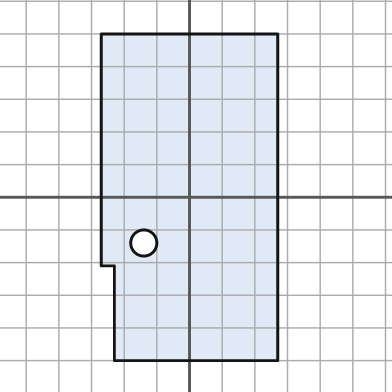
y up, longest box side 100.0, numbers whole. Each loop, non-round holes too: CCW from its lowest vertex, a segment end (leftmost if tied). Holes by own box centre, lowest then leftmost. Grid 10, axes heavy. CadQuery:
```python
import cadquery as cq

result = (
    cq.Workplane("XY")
    .moveTo(-23.0, -50.0)
    .lineTo(27.0, -50.0)
    .lineTo(27.0, 50.0)
    .lineTo(-27.0, 50.0)
    .lineTo(-27.0, -21.0)
    .lineTo(-23.0, -21.0)
    .close()
    .moveTo(-14.0, -14.0)
    .circle(4.0)
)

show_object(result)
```